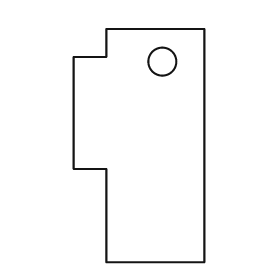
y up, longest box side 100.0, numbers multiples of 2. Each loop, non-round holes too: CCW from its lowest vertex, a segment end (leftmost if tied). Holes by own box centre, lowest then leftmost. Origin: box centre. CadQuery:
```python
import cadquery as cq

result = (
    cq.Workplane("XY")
    .moveTo(-14.0, -50.0)
    .lineTo(28.0, -50.0)
    .lineTo(28.0, 50.0)
    .lineTo(-14.0, 50.0)
    .lineTo(-14.0, 38.0)
    .lineTo(-28.0, 38.0)
    .lineTo(-28.0, -10.0)
    .lineTo(-14.0, -10.0)
    .close()
    .moveTo(10.0, 36.0)
    .circle(6.0)
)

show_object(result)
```